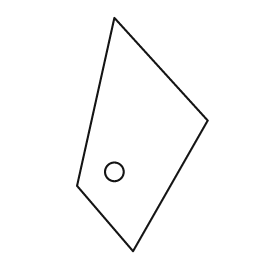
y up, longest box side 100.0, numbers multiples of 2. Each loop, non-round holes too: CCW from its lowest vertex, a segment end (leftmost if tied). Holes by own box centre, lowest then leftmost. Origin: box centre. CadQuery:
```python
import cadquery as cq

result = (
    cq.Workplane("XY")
    .moveTo(-4.0, -50.0)
    .lineTo(28.0, 6.0)
    .lineTo(-12.0, 50.0)
    .lineTo(-28.0, -22.0)
    .close()
    .moveTo(-12.0, -16.0)
    .circle(4.0)
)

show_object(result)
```